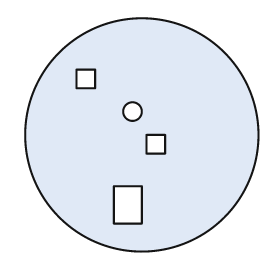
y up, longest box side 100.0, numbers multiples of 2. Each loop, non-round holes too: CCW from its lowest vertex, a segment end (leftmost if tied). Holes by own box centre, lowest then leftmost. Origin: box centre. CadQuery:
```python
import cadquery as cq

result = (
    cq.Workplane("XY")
    .moveTo(0.0, 0.0)
    .circle(50.0)
    .moveTo(-12.0, -38.0)
    .lineTo(0.0, -38.0)
    .lineTo(0.0, -22.0)
    .lineTo(-12.0, -22.0)
    .close()
    .moveTo(2.0, -8.0)
    .lineTo(10.0, -8.0)
    .lineTo(10.0, 0.0)
    .lineTo(2.0, 0.0)
    .close()
    .moveTo(-4.0, 10.0)
    .circle(4.0)
    .moveTo(-28.0, 20.0)
    .lineTo(-20.0, 20.0)
    .lineTo(-20.0, 28.0)
    .lineTo(-28.0, 28.0)
    .close()
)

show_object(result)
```